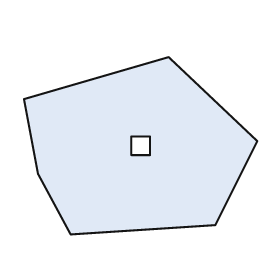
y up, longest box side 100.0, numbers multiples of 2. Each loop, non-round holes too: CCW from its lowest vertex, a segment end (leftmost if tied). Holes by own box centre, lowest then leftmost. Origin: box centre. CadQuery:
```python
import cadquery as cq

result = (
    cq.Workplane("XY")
    .moveTo(-30.0, -38.0)
    .lineTo(32.0, -34.0)
    .lineTo(50.0, 2.0)
    .lineTo(12.0, 38.0)
    .lineTo(-50.0, 20.0)
    .lineTo(-44.0, -12.0)
    .close()
    .moveTo(-4.0, -4.0)
    .lineTo(4.0, -4.0)
    .lineTo(4.0, 4.0)
    .lineTo(-4.0, 4.0)
    .close()
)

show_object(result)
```